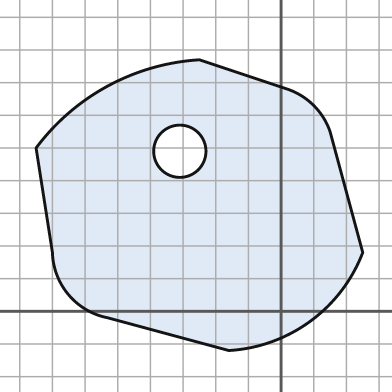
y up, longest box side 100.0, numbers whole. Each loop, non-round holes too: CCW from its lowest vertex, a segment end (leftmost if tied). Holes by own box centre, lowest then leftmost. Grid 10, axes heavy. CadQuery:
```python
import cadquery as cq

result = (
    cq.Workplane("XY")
    .moveTo(-16.0, -12.0)
    .threePointArc((9.0, -3.0), (25.0, 18.0))
    .lineTo(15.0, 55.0)
    .threePointArc((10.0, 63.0), (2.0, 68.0))
    .lineTo(-25.0, 77.0)
    .threePointArc((-53.0, 69.0), (-75.0, 50.0))
    .lineTo(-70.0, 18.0)
    .threePointArc((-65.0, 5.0), (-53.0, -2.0))
    .close()
    .moveTo(-31.0, 49.0)
    .circle(8.0)
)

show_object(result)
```